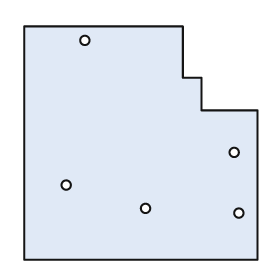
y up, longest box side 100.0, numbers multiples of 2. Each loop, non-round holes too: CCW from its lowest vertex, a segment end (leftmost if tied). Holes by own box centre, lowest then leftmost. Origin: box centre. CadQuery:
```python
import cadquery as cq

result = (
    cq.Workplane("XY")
    .moveTo(-50.0, -50.0)
    .lineTo(50.0, -50.0)
    .lineTo(50.0, 14.0)
    .lineTo(26.0, 14.0)
    .lineTo(26.0, 28.0)
    .lineTo(18.0, 28.0)
    .lineTo(18.0, 50.0)
    .lineTo(-50.0, 50.0)
    .close()
    .moveTo(42.0, -30.0)
    .circle(2.0)
    .moveTo(2.0, -28.0)
    .circle(2.0)
    .moveTo(-32.0, -18.0)
    .circle(2.0)
    .moveTo(40.0, -4.0)
    .circle(2.0)
    .moveTo(-24.0, 44.0)
    .circle(2.0)
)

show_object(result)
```